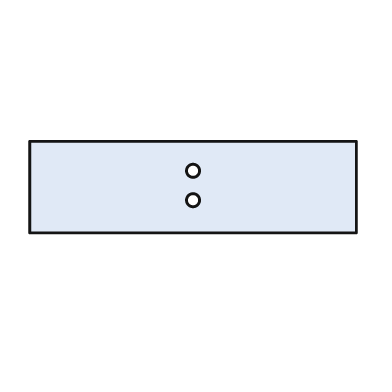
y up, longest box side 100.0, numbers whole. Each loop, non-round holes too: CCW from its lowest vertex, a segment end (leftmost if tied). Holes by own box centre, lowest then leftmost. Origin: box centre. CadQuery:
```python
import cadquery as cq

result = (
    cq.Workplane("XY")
    .moveTo(-50.0, -14.0)
    .lineTo(50.0, -14.0)
    .lineTo(50.0, 14.0)
    .lineTo(-50.0, 14.0)
    .close()
    .moveTo(0.0, -4.0)
    .circle(2.0)
    .moveTo(0.0, 5.0)
    .circle(2.0)
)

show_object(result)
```